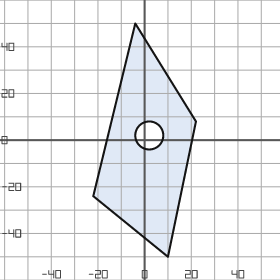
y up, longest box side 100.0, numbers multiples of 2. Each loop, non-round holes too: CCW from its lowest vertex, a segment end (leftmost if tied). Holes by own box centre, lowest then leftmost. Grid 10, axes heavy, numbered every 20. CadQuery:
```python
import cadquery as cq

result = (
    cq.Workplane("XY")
    .moveTo(10.0, -50.0)
    .lineTo(22.0, 8.0)
    .lineTo(-4.0, 50.0)
    .lineTo(-22.0, -24.0)
    .close()
    .moveTo(2.0, 2.0)
    .circle(6.0)
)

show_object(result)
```